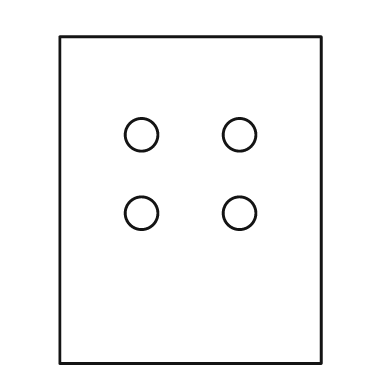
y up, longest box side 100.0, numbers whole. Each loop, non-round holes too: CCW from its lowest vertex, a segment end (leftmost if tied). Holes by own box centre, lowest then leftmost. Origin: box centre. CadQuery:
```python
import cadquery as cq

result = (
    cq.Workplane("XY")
    .moveTo(-40.0, -50.0)
    .lineTo(40.0, -50.0)
    .lineTo(40.0, 50.0)
    .lineTo(-40.0, 50.0)
    .close()
    .moveTo(-15.0, -4.0)
    .circle(5.0)
    .moveTo(15.0, -4.0)
    .circle(5.0)
    .moveTo(-15.0, 20.0)
    .circle(5.0)
    .moveTo(15.0, 20.0)
    .circle(5.0)
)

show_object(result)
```